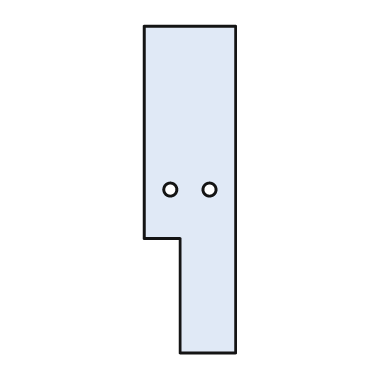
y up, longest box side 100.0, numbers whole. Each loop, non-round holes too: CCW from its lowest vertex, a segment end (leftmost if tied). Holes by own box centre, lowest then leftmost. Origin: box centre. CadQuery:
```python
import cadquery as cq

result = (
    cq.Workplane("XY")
    .moveTo(-3.0, -50.0)
    .lineTo(14.0, -50.0)
    .lineTo(14.0, 50.0)
    .lineTo(-14.0, 50.0)
    .lineTo(-14.0, -15.0)
    .lineTo(-3.0, -15.0)
    .close()
    .moveTo(-6.0, 0.0)
    .circle(2.0)
    .moveTo(6.0, 0.0)
    .circle(2.0)
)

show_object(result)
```